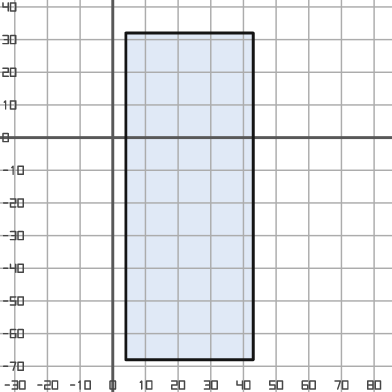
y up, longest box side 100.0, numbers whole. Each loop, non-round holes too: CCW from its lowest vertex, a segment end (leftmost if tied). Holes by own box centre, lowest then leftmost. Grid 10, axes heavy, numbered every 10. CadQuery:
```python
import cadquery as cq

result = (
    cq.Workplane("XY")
    .moveTo(4.0, -68.0)
    .lineTo(43.0, -68.0)
    .lineTo(43.0, 32.0)
    .lineTo(4.0, 32.0)
    .close()
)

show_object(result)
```